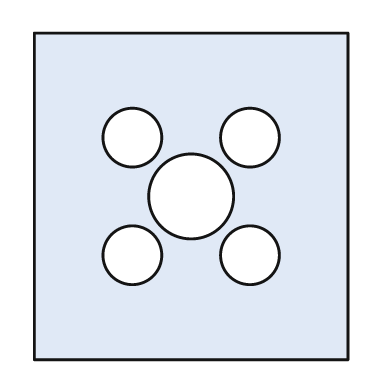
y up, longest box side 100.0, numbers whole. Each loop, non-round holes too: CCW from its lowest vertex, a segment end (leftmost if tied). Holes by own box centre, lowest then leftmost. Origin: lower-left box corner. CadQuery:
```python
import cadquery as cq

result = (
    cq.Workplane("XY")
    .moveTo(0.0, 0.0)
    .lineTo(96.0, 0.0)
    .lineTo(96.0, 100.0)
    .lineTo(0.0, 100.0)
    .close()
    .moveTo(30.0, 32.0)
    .circle(9.0)
    .moveTo(66.0, 32.0)
    .circle(9.0)
    .moveTo(48.0, 50.0)
    .circle(13.0)
    .moveTo(30.0, 68.0)
    .circle(9.0)
    .moveTo(66.0, 68.0)
    .circle(9.0)
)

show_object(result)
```